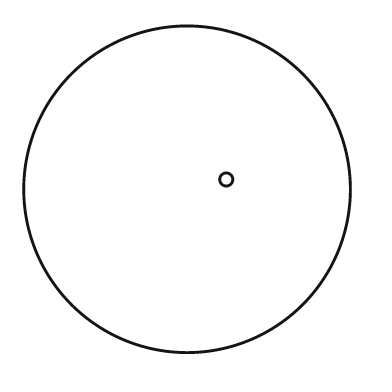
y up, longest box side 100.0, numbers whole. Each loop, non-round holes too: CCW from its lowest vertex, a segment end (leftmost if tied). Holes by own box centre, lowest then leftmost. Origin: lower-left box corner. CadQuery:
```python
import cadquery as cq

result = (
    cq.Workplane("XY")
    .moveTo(50.0, 50.0)
    .circle(50.0)
    .moveTo(62.0, 53.0)
    .circle(2.0)
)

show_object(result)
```